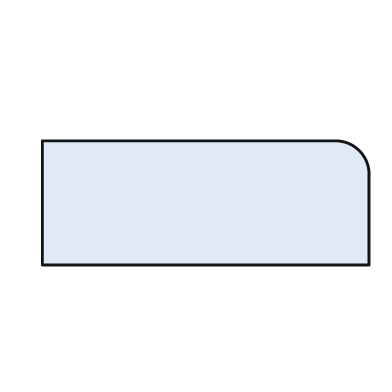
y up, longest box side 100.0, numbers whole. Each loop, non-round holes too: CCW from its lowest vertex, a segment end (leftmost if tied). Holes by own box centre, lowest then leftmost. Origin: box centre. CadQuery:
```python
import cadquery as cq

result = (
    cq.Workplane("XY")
    .moveTo(-50.0, -19.0)
    .lineTo(50.0, -19.0)
    .lineTo(50.0, 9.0)
    .threePointArc((47.0, 16.0), (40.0, 19.0))
    .lineTo(-50.0, 19.0)
    .close()
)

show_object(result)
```